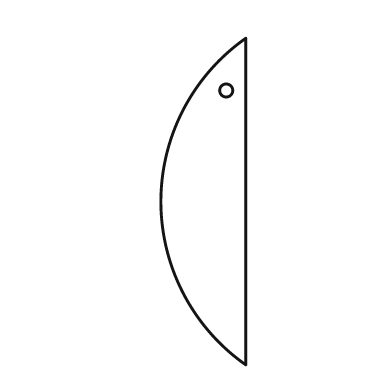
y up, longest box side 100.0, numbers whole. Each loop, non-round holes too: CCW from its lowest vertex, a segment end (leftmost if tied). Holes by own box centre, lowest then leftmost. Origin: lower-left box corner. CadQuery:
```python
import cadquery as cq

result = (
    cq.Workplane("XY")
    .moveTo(26.0, 0.0)
    .lineTo(26.0, 100.0)
    .threePointArc((0.0, 50.0), (26.0, 0.0))
    .close()
    .moveTo(20.0, 84.0)
    .circle(2.0)
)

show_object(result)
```